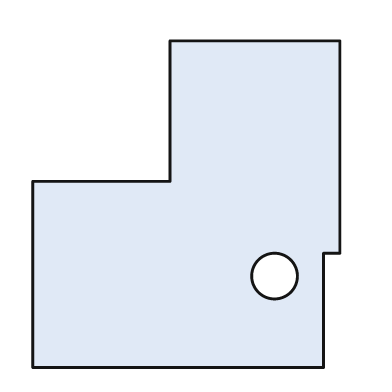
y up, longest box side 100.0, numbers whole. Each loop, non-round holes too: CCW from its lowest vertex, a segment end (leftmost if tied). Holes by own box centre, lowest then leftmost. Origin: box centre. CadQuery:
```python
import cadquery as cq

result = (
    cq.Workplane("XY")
    .moveTo(-47.0, -50.0)
    .lineTo(42.0, -50.0)
    .lineTo(42.0, -15.0)
    .lineTo(47.0, -15.0)
    .lineTo(47.0, 50.0)
    .lineTo(-5.0, 50.0)
    .lineTo(-5.0, 7.0)
    .lineTo(-47.0, 7.0)
    .close()
    .moveTo(27.0, -22.0)
    .circle(7.0)
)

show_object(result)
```